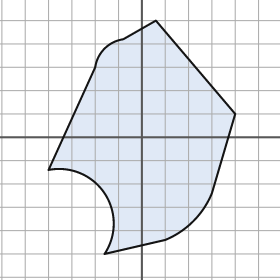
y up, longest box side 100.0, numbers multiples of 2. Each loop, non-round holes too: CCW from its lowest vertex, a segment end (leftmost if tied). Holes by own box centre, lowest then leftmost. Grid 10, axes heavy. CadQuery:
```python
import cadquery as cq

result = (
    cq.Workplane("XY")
    .moveTo(-16.0, -50.0)
    .lineTo(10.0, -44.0)
    .threePointArc((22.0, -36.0), (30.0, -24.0))
    .lineTo(40.0, 10.0)
    .lineTo(6.0, 50.0)
    .lineTo(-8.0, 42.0)
    .threePointArc((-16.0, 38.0), (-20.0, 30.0))
    .lineTo(-40.0, -14.0)
    .threePointArc((-16.0, -24.0), (-16.0, -50.0))
    .close()
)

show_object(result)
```